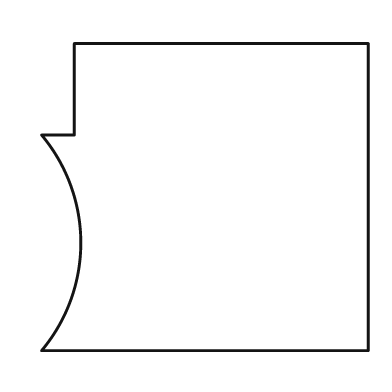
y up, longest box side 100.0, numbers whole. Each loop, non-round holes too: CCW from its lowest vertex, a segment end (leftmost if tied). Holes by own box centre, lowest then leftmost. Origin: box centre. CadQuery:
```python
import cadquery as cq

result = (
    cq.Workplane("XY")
    .moveTo(-50.0, -47.0)
    .lineTo(50.0, -47.0)
    .lineTo(50.0, 47.0)
    .lineTo(-40.0, 47.0)
    .lineTo(-40.0, 19.0)
    .lineTo(-50.0, 19.0)
    .threePointArc((-38.0, -14.0), (-50.0, -47.0))
    .close()
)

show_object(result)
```